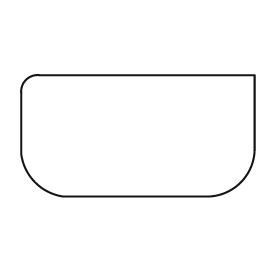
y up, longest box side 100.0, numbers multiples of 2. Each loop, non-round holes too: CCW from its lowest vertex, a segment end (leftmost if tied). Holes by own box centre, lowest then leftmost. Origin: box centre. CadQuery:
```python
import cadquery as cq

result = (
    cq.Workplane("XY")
    .moveTo(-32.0, -26.0)
    .lineTo(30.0, -26.0)
    .threePointArc((44.0, -20.0), (50.0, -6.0))
    .lineTo(50.0, 26.0)
    .lineTo(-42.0, 26.0)
    .threePointArc((-48.0, 24.0), (-50.0, 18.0))
    .lineTo(-50.0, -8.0)
    .threePointArc((-44.0, -20.0), (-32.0, -26.0))
    .close()
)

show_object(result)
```